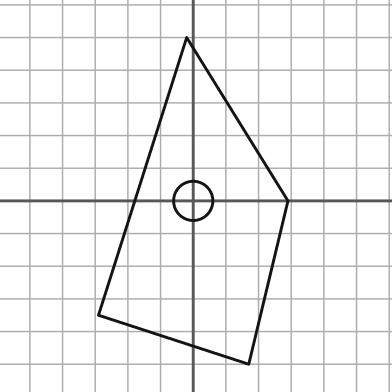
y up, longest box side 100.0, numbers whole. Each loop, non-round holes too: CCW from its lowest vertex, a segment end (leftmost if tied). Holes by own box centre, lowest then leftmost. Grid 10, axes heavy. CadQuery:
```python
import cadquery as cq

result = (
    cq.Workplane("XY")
    .moveTo(17.0, -50.0)
    .lineTo(29.0, 0.0)
    .lineTo(-2.0, 50.0)
    .lineTo(-29.0, -35.0)
    .close()
    .moveTo(0.0, 0.0)
    .circle(6.0)
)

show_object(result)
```